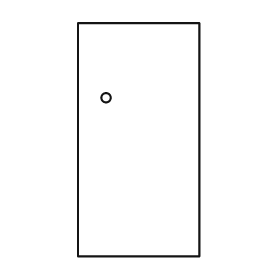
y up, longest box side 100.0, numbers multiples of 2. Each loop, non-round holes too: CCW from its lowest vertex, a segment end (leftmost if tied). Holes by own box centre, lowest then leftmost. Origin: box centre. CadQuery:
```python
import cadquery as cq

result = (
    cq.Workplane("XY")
    .moveTo(-26.0, -50.0)
    .lineTo(26.0, -50.0)
    .lineTo(26.0, 50.0)
    .lineTo(-26.0, 50.0)
    .close()
    .moveTo(-14.0, 18.0)
    .circle(2.0)
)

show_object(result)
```